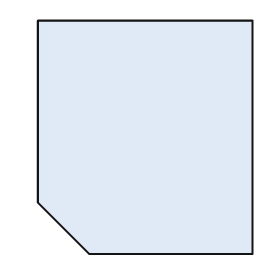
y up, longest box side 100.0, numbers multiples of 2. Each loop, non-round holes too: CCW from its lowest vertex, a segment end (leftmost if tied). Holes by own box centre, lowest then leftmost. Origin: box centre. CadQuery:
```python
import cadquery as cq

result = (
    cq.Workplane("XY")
    .moveTo(-24.0, -50.0)
    .lineTo(46.0, -50.0)
    .lineTo(46.0, 50.0)
    .lineTo(-46.0, 50.0)
    .lineTo(-46.0, -28.0)
    .close()
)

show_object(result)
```